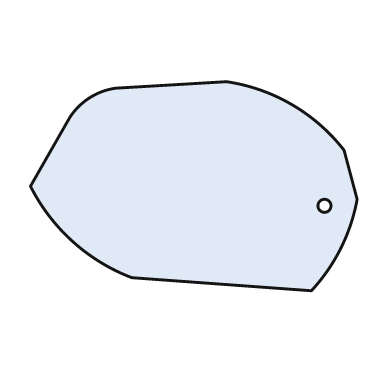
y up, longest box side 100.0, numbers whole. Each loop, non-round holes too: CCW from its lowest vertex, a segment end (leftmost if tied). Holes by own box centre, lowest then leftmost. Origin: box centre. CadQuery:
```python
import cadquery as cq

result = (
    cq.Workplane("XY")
    .moveTo(36.0, -32.0)
    .threePointArc((45.0, -19.0), (50.0, -4.0))
    .lineTo(46.0, 11.0)
    .threePointArc((30.0, 25.0), (10.0, 32.0))
    .lineTo(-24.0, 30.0)
    .threePointArc((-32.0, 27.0), (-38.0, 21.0))
    .lineTo(-50.0, 0.0)
    .threePointArc((-37.0, -17.0), (-19.0, -28.0))
    .close()
    .moveTo(40.0, -6.0)
    .circle(2.0)
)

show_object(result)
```